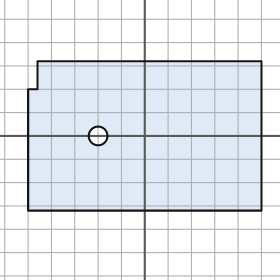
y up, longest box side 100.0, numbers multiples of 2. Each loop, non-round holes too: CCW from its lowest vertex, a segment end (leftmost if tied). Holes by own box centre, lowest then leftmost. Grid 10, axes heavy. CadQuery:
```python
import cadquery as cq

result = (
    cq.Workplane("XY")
    .moveTo(-50.0, -32.0)
    .lineTo(50.0, -32.0)
    .lineTo(50.0, 32.0)
    .lineTo(-46.0, 32.0)
    .lineTo(-46.0, 20.0)
    .lineTo(-50.0, 20.0)
    .close()
    .moveTo(-20.0, 0.0)
    .circle(4.0)
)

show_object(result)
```